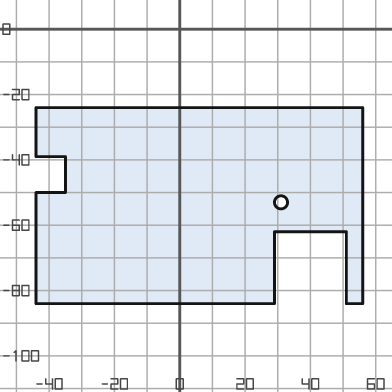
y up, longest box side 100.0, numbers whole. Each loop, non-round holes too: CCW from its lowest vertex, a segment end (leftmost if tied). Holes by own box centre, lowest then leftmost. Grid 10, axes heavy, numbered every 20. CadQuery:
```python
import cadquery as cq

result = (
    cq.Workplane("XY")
    .moveTo(-44.0, -84.0)
    .lineTo(29.0, -84.0)
    .lineTo(29.0, -62.0)
    .lineTo(51.0, -62.0)
    .lineTo(51.0, -84.0)
    .lineTo(56.0, -84.0)
    .lineTo(56.0, -24.0)
    .lineTo(-44.0, -24.0)
    .lineTo(-44.0, -39.0)
    .lineTo(-35.0, -39.0)
    .lineTo(-35.0, -50.0)
    .lineTo(-44.0, -50.0)
    .close()
    .moveTo(31.0, -53.0)
    .circle(2.0)
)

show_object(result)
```